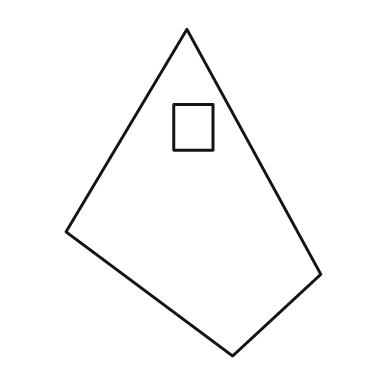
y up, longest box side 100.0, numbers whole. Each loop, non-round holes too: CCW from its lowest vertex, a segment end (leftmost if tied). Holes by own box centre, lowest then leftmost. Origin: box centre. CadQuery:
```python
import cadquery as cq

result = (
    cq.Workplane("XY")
    .moveTo(12.0, -50.0)
    .lineTo(39.0, -25.0)
    .lineTo(-2.0, 50.0)
    .lineTo(-39.0, -12.0)
    .close()
    .moveTo(-6.0, 13.0)
    .lineTo(6.0, 13.0)
    .lineTo(6.0, 27.0)
    .lineTo(-6.0, 27.0)
    .close()
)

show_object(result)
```